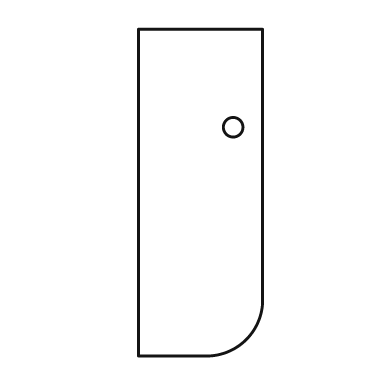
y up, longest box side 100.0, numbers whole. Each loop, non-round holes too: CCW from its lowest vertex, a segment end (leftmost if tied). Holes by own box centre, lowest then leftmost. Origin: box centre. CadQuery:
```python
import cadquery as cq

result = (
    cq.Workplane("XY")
    .moveTo(-19.0, -50.0)
    .lineTo(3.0, -50.0)
    .threePointArc((14.0, -45.0), (19.0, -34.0))
    .lineTo(19.0, 50.0)
    .lineTo(-19.0, 50.0)
    .close()
    .moveTo(10.0, 20.0)
    .circle(3.0)
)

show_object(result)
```